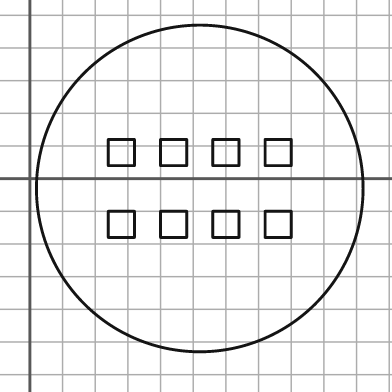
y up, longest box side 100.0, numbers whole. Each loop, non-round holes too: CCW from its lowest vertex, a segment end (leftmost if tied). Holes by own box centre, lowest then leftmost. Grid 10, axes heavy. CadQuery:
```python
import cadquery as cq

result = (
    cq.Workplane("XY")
    .moveTo(52.0, -3.0)
    .circle(50.0)
    .moveTo(24.0, -18.0)
    .lineTo(32.0, -18.0)
    .lineTo(32.0, -10.0)
    .lineTo(24.0, -10.0)
    .close()
    .moveTo(40.0, -18.0)
    .lineTo(48.0, -18.0)
    .lineTo(48.0, -10.0)
    .lineTo(40.0, -10.0)
    .close()
    .moveTo(56.0, -18.0)
    .lineTo(64.0, -18.0)
    .lineTo(64.0, -10.0)
    .lineTo(56.0, -10.0)
    .close()
    .moveTo(72.0, -18.0)
    .lineTo(80.0, -18.0)
    .lineTo(80.0, -10.0)
    .lineTo(72.0, -10.0)
    .close()
    .moveTo(24.0, 4.0)
    .lineTo(32.0, 4.0)
    .lineTo(32.0, 12.0)
    .lineTo(24.0, 12.0)
    .close()
    .moveTo(40.0, 4.0)
    .lineTo(48.0, 4.0)
    .lineTo(48.0, 12.0)
    .lineTo(40.0, 12.0)
    .close()
    .moveTo(56.0, 4.0)
    .lineTo(64.0, 4.0)
    .lineTo(64.0, 12.0)
    .lineTo(56.0, 12.0)
    .close()
    .moveTo(72.0, 4.0)
    .lineTo(80.0, 4.0)
    .lineTo(80.0, 12.0)
    .lineTo(72.0, 12.0)
    .close()
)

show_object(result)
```